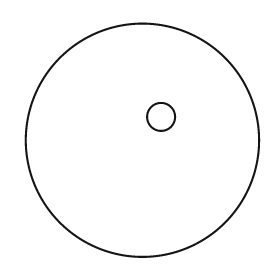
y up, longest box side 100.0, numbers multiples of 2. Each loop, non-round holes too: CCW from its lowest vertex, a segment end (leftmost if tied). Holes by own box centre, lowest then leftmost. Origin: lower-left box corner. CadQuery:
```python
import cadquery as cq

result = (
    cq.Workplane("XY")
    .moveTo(50.0, 50.0)
    .circle(50.0)
    .moveTo(58.0, 60.0)
    .circle(6.0)
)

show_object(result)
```